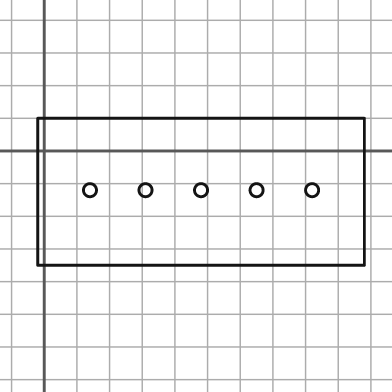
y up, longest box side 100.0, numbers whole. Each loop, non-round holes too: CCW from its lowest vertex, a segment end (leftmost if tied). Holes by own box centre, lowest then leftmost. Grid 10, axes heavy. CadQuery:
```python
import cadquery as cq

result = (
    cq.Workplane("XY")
    .moveTo(-2.0, -35.0)
    .lineTo(98.0, -35.0)
    .lineTo(98.0, 10.0)
    .lineTo(-2.0, 10.0)
    .close()
    .moveTo(14.0, -12.0)
    .circle(2.0)
    .moveTo(31.0, -12.0)
    .circle(2.0)
    .moveTo(48.0, -12.0)
    .circle(2.0)
    .moveTo(65.0, -12.0)
    .circle(2.0)
    .moveTo(82.0, -12.0)
    .circle(2.0)
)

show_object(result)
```